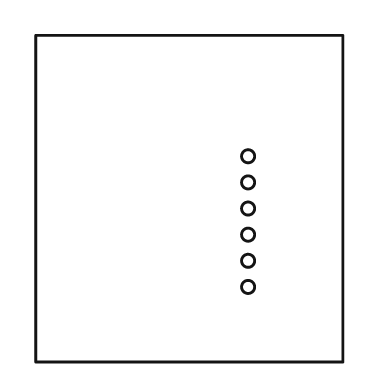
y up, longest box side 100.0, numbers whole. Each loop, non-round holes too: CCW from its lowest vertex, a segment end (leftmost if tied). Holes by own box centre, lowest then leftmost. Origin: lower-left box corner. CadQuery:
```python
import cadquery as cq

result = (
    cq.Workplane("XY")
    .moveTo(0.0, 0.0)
    .lineTo(94.0, 0.0)
    .lineTo(94.0, 100.0)
    .lineTo(0.0, 100.0)
    .close()
    .moveTo(65.0, 23.0)
    .circle(2.0)
    .moveTo(65.0, 31.0)
    .circle(2.0)
    .moveTo(65.0, 39.0)
    .circle(2.0)
    .moveTo(65.0, 47.0)
    .circle(2.0)
    .moveTo(65.0, 55.0)
    .circle(2.0)
    .moveTo(65.0, 63.0)
    .circle(2.0)
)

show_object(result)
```